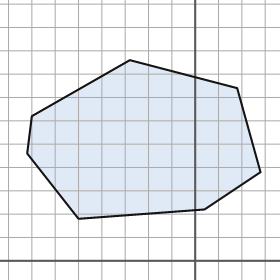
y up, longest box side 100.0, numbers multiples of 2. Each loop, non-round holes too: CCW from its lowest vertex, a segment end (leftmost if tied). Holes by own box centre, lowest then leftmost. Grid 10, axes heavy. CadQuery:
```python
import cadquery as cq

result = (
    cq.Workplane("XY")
    .moveTo(-50.0, 18.0)
    .lineTo(4.0, 22.0)
    .lineTo(28.0, 38.0)
    .lineTo(18.0, 74.0)
    .lineTo(-28.0, 86.0)
    .lineTo(-70.0, 62.0)
    .lineTo(-72.0, 46.0)
    .close()
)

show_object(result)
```